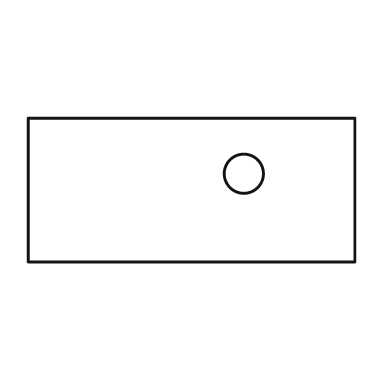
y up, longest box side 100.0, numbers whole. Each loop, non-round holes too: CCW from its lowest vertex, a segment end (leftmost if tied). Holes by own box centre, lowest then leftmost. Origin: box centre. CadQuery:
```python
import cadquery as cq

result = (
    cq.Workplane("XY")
    .moveTo(-50.0, -22.0)
    .lineTo(50.0, -22.0)
    .lineTo(50.0, 22.0)
    .lineTo(-50.0, 22.0)
    .close()
    .moveTo(16.0, 5.0)
    .circle(6.0)
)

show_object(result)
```